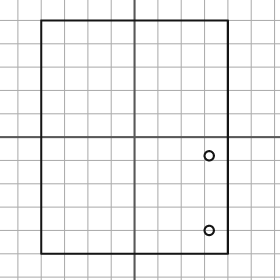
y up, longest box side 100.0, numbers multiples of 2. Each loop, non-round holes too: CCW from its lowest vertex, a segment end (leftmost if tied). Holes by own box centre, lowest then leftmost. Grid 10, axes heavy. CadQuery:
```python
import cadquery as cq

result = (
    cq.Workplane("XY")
    .moveTo(-40.0, -50.0)
    .lineTo(40.0, -50.0)
    .lineTo(40.0, 50.0)
    .lineTo(-40.0, 50.0)
    .close()
    .moveTo(32.0, -40.0)
    .circle(2.0)
    .moveTo(32.0, -8.0)
    .circle(2.0)
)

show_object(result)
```